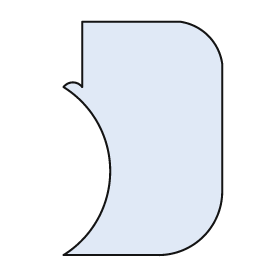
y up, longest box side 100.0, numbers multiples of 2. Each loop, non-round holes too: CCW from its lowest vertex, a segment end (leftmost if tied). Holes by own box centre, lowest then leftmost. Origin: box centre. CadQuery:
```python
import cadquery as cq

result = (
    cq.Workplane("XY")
    .moveTo(-34.0, -50.0)
    .lineTo(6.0, -50.0)
    .threePointArc((26.0, -42.0), (34.0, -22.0))
    .lineTo(34.0, 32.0)
    .threePointArc((28.0, 44.0), (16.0, 50.0))
    .lineTo(-26.0, 50.0)
    .lineTo(-26.0, 22.0)
    .threePointArc((-30.0, 24.0), (-34.0, 22.0))
    .threePointArc((-14.0, -14.0), (-34.0, -50.0))
    .close()
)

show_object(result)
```